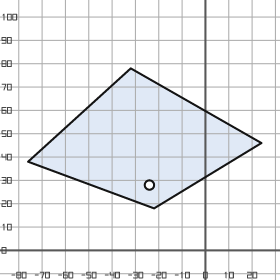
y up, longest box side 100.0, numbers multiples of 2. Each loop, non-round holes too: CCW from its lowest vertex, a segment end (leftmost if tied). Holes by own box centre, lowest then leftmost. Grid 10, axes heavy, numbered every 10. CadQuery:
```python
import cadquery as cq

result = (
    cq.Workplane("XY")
    .moveTo(-22.0, 18.0)
    .lineTo(24.0, 46.0)
    .lineTo(-32.0, 78.0)
    .lineTo(-76.0, 38.0)
    .close()
    .moveTo(-24.0, 28.0)
    .circle(2.0)
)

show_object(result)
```